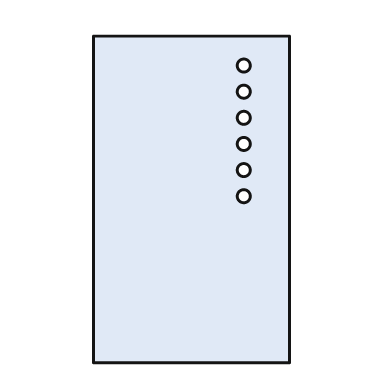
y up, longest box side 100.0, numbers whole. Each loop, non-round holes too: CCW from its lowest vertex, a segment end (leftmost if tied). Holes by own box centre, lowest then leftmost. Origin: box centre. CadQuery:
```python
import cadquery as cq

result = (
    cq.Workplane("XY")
    .moveTo(-30.0, -50.0)
    .lineTo(30.0, -50.0)
    .lineTo(30.0, 50.0)
    .lineTo(-30.0, 50.0)
    .close()
    .moveTo(16.0, 1.0)
    .circle(2.0)
    .moveTo(16.0, 9.0)
    .circle(2.0)
    .moveTo(16.0, 17.0)
    .circle(2.0)
    .moveTo(16.0, 25.0)
    .circle(2.0)
    .moveTo(16.0, 33.0)
    .circle(2.0)
    .moveTo(16.0, 41.0)
    .circle(2.0)
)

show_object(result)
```